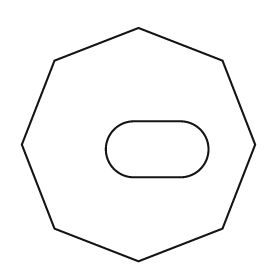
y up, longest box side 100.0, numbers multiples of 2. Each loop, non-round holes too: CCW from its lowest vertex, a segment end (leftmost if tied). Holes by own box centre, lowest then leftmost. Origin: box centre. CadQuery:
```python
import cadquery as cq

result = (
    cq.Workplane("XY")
    .moveTo(0.0, -50.0)
    .lineTo(36.0, -36.0)
    .lineTo(50.0, 0.0)
    .lineTo(36.0, 36.0)
    .lineTo(0.0, 50.0)
    .lineTo(-36.0, 36.0)
    .lineTo(-50.0, 0.0)
    .lineTo(-36.0, -36.0)
    .close()
    .moveTo(-2.0, -14.0)
    .lineTo(18.0, -14.0)
    .threePointArc((30.0, -2.0), (18.0, 10.0))
    .lineTo(-2.0, 10.0)
    .threePointArc((-14.0, -2.0), (-2.0, -14.0))
    .close()
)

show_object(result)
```